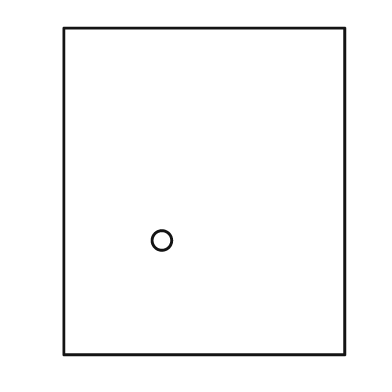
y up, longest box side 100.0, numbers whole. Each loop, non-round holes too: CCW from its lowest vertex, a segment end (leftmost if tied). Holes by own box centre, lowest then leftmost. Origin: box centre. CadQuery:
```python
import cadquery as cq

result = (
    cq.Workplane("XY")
    .moveTo(-43.0, -50.0)
    .lineTo(43.0, -50.0)
    .lineTo(43.0, 50.0)
    .lineTo(-43.0, 50.0)
    .close()
    .moveTo(-13.0, -15.0)
    .circle(3.0)
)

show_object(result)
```